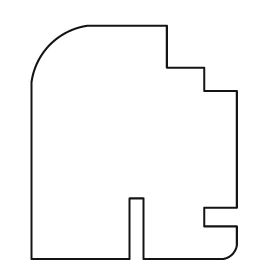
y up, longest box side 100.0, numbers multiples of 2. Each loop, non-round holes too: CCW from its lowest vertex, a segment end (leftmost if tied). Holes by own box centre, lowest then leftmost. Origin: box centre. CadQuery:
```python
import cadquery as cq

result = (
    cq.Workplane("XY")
    .moveTo(-44.0, -50.0)
    .lineTo(-2.0, -50.0)
    .lineTo(-2.0, -24.0)
    .lineTo(4.0, -24.0)
    .lineTo(4.0, -50.0)
    .lineTo(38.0, -50.0)
    .threePointArc((42.0, -48.0), (44.0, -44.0))
    .lineTo(44.0, -36.0)
    .lineTo(30.0, -36.0)
    .lineTo(30.0, -28.0)
    .lineTo(44.0, -28.0)
    .lineTo(44.0, 22.0)
    .lineTo(30.0, 22.0)
    .lineTo(30.0, 32.0)
    .lineTo(14.0, 32.0)
    .lineTo(14.0, 50.0)
    .lineTo(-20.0, 50.0)
    .threePointArc((-36.0, 42.0), (-44.0, 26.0))
    .close()
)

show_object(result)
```